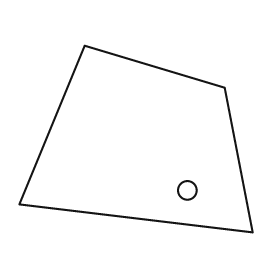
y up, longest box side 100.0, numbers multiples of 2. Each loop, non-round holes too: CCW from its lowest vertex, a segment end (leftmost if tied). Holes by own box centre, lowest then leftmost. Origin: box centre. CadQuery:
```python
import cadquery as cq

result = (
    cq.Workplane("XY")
    .moveTo(50.0, -40.0)
    .lineTo(38.0, 22.0)
    .lineTo(-22.0, 40.0)
    .lineTo(-50.0, -28.0)
    .close()
    .moveTo(22.0, -22.0)
    .circle(4.0)
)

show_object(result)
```